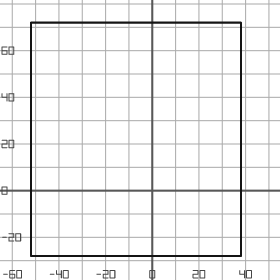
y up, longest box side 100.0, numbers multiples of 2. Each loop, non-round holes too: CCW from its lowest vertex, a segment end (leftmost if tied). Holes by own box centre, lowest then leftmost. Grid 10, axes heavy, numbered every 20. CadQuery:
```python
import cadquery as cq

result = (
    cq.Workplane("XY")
    .moveTo(-52.0, -28.0)
    .lineTo(38.0, -28.0)
    .lineTo(38.0, 72.0)
    .lineTo(-52.0, 72.0)
    .close()
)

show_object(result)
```